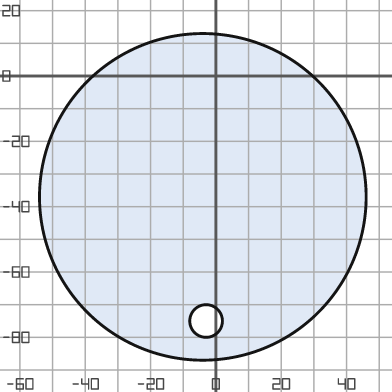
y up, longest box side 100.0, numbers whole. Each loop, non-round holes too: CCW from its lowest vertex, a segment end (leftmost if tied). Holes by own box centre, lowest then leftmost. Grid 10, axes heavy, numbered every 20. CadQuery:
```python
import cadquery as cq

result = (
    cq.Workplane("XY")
    .moveTo(-4.0, -37.0)
    .circle(50.0)
    .moveTo(-3.0, -75.0)
    .circle(5.0)
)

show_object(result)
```